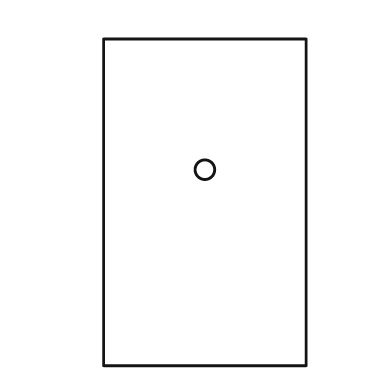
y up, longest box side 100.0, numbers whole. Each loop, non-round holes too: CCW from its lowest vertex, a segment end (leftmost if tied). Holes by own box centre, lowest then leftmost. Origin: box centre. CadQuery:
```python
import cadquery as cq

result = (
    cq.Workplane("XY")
    .moveTo(-31.0, -50.0)
    .lineTo(31.0, -50.0)
    .lineTo(31.0, 50.0)
    .lineTo(-31.0, 50.0)
    .close()
    .moveTo(0.0, 10.0)
    .circle(3.0)
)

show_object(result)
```